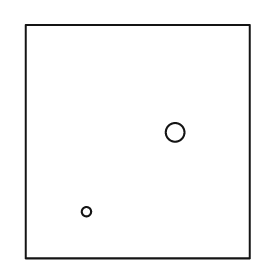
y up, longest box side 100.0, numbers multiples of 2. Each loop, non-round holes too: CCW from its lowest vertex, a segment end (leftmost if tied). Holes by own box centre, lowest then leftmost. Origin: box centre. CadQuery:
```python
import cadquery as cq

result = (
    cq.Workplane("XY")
    .moveTo(-48.0, -50.0)
    .lineTo(48.0, -50.0)
    .lineTo(48.0, 50.0)
    .lineTo(-48.0, 50.0)
    .close()
    .moveTo(-22.0, -30.0)
    .circle(2.0)
    .moveTo(16.0, 4.0)
    .circle(4.0)
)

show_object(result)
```